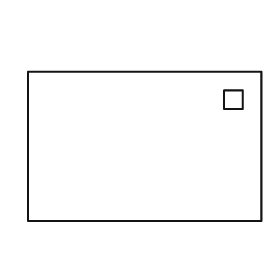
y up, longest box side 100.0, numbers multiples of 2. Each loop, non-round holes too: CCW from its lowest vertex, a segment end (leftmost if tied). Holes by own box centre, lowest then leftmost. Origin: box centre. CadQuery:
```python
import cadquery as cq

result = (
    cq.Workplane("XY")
    .moveTo(-50.0, -32.0)
    .lineTo(50.0, -32.0)
    .lineTo(50.0, 32.0)
    .lineTo(-50.0, 32.0)
    .close()
    .moveTo(34.0, 16.0)
    .lineTo(42.0, 16.0)
    .lineTo(42.0, 24.0)
    .lineTo(34.0, 24.0)
    .close()
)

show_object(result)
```